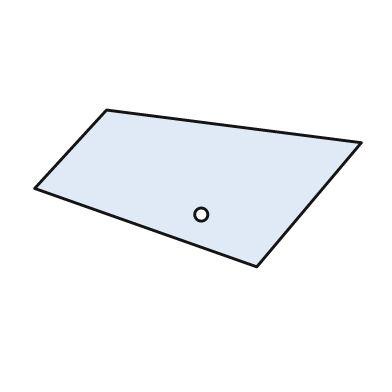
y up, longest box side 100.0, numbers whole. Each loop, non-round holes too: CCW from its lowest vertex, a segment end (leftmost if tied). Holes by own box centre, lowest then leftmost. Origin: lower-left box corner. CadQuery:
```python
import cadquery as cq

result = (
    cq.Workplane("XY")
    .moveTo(68.0, 0.0)
    .lineTo(100.0, 38.0)
    .lineTo(22.0, 48.0)
    .lineTo(0.0, 24.0)
    .close()
    .moveTo(51.0, 16.0)
    .circle(2.0)
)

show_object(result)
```